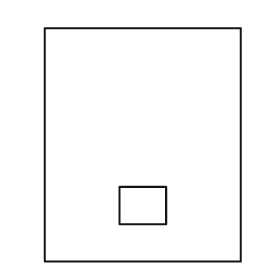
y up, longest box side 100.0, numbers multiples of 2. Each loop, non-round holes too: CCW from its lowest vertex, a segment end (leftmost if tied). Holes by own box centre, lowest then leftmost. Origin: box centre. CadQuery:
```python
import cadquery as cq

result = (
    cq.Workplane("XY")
    .moveTo(-42.0, -50.0)
    .lineTo(42.0, -50.0)
    .lineTo(42.0, 50.0)
    .lineTo(-42.0, 50.0)
    .close()
    .moveTo(-10.0, -34.0)
    .lineTo(10.0, -34.0)
    .lineTo(10.0, -18.0)
    .lineTo(-10.0, -18.0)
    .close()
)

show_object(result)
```